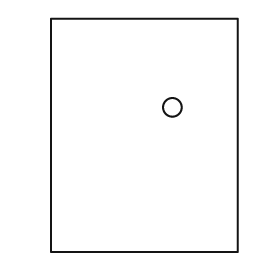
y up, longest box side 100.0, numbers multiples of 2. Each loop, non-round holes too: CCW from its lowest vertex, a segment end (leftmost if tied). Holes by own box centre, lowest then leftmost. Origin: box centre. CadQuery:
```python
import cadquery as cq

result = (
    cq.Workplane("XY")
    .moveTo(-40.0, -50.0)
    .lineTo(40.0, -50.0)
    .lineTo(40.0, 50.0)
    .lineTo(-40.0, 50.0)
    .close()
    .moveTo(12.0, 12.0)
    .circle(4.0)
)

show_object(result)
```